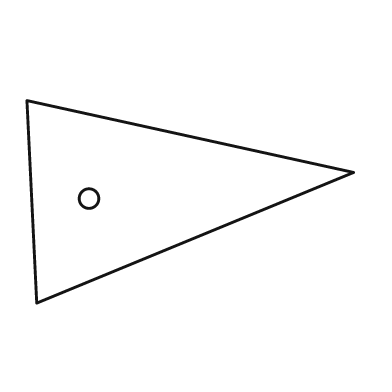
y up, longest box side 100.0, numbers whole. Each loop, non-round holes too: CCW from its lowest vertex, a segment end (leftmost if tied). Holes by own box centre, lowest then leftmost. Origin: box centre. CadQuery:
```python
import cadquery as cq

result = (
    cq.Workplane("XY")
    .moveTo(-47.0, -31.0)
    .lineTo(50.0, 9.0)
    .lineTo(-50.0, 31.0)
    .close()
    .moveTo(-31.0, 1.0)
    .circle(3.0)
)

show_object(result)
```